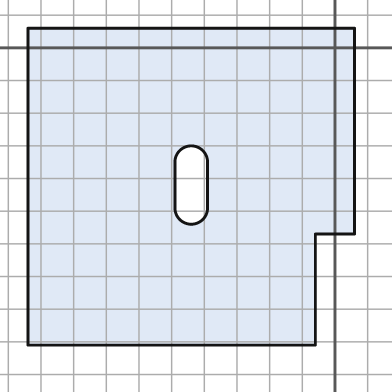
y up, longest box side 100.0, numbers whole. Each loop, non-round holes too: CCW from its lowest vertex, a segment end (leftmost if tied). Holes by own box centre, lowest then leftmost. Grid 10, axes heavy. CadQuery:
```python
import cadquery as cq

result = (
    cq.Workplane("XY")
    .moveTo(-94.0, -91.0)
    .lineTo(-6.0, -91.0)
    .lineTo(-6.0, -57.0)
    .lineTo(6.0, -57.0)
    .lineTo(6.0, 6.0)
    .lineTo(-94.0, 6.0)
    .close()
    .moveTo(-49.0, -49.0)
    .threePointArc((-44.0, -54.0), (-39.0, -49.0))
    .lineTo(-39.0, -35.0)
    .threePointArc((-44.0, -30.0), (-49.0, -35.0))
    .close()
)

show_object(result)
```